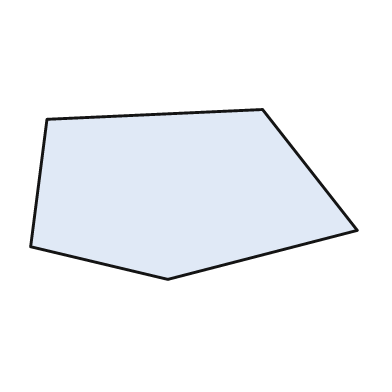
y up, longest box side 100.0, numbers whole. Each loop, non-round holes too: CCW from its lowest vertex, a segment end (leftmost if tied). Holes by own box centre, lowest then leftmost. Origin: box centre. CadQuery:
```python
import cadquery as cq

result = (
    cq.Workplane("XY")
    .moveTo(-8.0, -26.0)
    .lineTo(50.0, -11.0)
    .lineTo(21.0, 26.0)
    .lineTo(-45.0, 23.0)
    .lineTo(-50.0, -16.0)
    .close()
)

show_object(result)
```